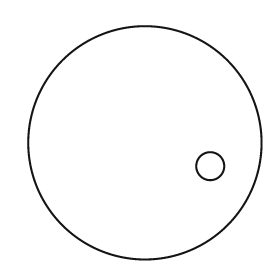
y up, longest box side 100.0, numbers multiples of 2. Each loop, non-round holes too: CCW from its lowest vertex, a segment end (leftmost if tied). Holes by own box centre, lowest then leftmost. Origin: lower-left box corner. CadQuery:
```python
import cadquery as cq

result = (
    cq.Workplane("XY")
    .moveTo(50.0, 50.0)
    .circle(50.0)
    .moveTo(78.0, 40.0)
    .circle(6.0)
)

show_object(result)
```